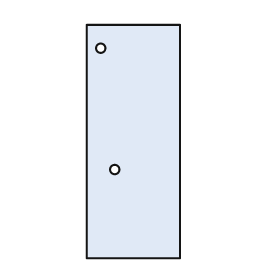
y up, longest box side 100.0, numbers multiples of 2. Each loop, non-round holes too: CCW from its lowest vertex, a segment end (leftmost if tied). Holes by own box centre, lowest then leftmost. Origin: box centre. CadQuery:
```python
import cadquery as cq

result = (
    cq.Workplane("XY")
    .moveTo(-20.0, -50.0)
    .lineTo(20.0, -50.0)
    .lineTo(20.0, 50.0)
    .lineTo(-20.0, 50.0)
    .close()
    .moveTo(-8.0, -12.0)
    .circle(2.0)
    .moveTo(-14.0, 40.0)
    .circle(2.0)
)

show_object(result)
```